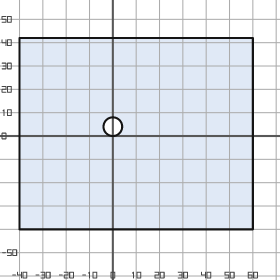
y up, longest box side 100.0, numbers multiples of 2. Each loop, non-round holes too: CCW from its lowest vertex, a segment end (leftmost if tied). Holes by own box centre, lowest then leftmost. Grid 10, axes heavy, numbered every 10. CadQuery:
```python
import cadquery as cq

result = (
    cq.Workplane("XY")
    .moveTo(-40.0, -40.0)
    .lineTo(60.0, -40.0)
    .lineTo(60.0, 42.0)
    .lineTo(-40.0, 42.0)
    .close()
    .moveTo(0.0, 4.0)
    .circle(4.0)
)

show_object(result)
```